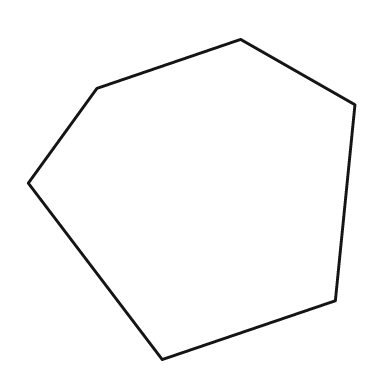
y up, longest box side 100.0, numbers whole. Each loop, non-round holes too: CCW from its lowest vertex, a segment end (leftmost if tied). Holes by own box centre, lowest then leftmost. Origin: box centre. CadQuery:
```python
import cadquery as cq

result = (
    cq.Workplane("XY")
    .moveTo(-9.0, -49.0)
    .lineTo(44.0, -31.0)
    .lineTo(50.0, 29.0)
    .lineTo(15.0, 49.0)
    .lineTo(-29.0, 34.0)
    .lineTo(-50.0, 5.0)
    .close()
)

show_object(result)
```